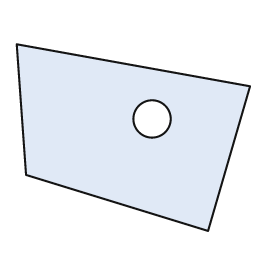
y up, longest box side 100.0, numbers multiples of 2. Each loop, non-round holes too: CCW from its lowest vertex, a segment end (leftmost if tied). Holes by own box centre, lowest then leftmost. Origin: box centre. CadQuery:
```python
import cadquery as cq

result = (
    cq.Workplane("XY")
    .moveTo(32.0, -40.0)
    .lineTo(50.0, 22.0)
    .lineTo(-50.0, 40.0)
    .lineTo(-46.0, -16.0)
    .close()
    .moveTo(8.0, 8.0)
    .circle(8.0)
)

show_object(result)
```